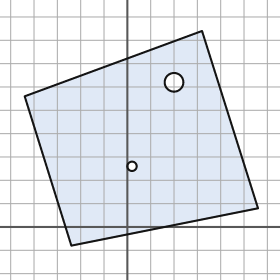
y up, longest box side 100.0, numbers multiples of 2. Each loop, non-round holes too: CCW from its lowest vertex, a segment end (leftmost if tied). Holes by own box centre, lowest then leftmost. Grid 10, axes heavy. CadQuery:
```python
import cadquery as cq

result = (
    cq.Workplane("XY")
    .moveTo(-24.0, -8.0)
    .lineTo(56.0, 8.0)
    .lineTo(32.0, 84.0)
    .lineTo(-44.0, 56.0)
    .close()
    .moveTo(2.0, 26.0)
    .circle(2.0)
    .moveTo(20.0, 62.0)
    .circle(4.0)
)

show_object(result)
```